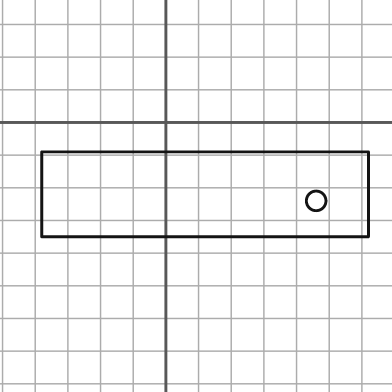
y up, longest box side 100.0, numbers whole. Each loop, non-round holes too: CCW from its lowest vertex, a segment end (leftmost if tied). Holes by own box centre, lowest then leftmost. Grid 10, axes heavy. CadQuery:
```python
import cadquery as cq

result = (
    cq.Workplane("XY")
    .moveTo(-38.0, -35.0)
    .lineTo(62.0, -35.0)
    .lineTo(62.0, -9.0)
    .lineTo(-38.0, -9.0)
    .close()
    .moveTo(46.0, -24.0)
    .circle(3.0)
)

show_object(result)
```